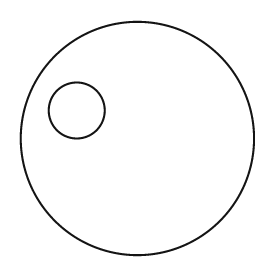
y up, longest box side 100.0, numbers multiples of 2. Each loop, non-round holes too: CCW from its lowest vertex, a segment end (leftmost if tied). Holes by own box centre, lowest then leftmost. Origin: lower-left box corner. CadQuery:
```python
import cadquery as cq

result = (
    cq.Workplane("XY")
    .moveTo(50.0, 50.0)
    .circle(50.0)
    .moveTo(24.0, 62.0)
    .circle(12.0)
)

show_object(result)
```